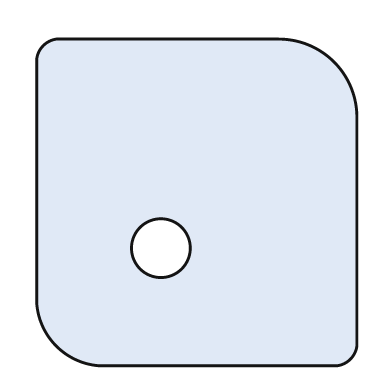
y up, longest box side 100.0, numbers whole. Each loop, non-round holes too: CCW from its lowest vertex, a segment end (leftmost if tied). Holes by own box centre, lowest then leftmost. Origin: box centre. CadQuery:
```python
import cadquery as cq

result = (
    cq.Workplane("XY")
    .moveTo(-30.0, -50.0)
    .lineTo(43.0, -50.0)
    .threePointArc((47.0, -48.0), (49.0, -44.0))
    .lineTo(49.0, 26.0)
    .threePointArc((42.0, 43.0), (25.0, 50.0))
    .lineTo(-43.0, 50.0)
    .threePointArc((-47.0, 48.0), (-49.0, 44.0))
    .lineTo(-49.0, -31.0)
    .threePointArc((-43.0, -44.0), (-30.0, -50.0))
    .close()
    .moveTo(-11.0, -14.0)
    .circle(9.0)
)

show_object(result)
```